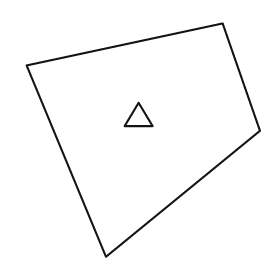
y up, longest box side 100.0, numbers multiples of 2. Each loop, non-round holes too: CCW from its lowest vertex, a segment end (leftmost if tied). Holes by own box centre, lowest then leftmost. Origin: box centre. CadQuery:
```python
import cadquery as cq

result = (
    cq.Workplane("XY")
    .moveTo(-16.0, -50.0)
    .lineTo(50.0, 4.0)
    .lineTo(34.0, 50.0)
    .lineTo(-50.0, 32.0)
    .close()
    .moveTo(-8.0, 6.0)
    .lineTo(4.0, 6.0)
    .lineTo(-2.0, 16.0)
    .close()
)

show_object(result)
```